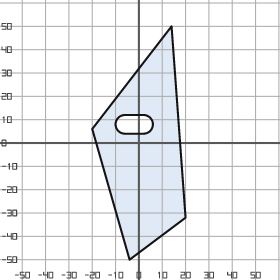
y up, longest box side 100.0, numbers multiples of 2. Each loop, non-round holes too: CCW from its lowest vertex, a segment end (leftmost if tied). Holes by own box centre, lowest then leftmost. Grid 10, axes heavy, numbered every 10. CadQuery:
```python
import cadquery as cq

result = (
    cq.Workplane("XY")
    .moveTo(-4.0, -50.0)
    .lineTo(20.0, -32.0)
    .lineTo(14.0, 50.0)
    .lineTo(-20.0, 6.0)
    .close()
    .moveTo(-6.0, 4.0)
    .lineTo(2.0, 4.0)
    .threePointArc((6.0, 8.0), (2.0, 12.0))
    .lineTo(-6.0, 12.0)
    .threePointArc((-10.0, 8.0), (-6.0, 4.0))
    .close()
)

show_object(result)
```